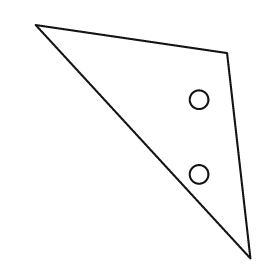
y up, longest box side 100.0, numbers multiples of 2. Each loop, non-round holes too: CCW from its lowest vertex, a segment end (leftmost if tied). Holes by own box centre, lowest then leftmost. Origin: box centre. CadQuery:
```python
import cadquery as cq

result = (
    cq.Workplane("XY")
    .moveTo(46.0, -50.0)
    .lineTo(36.0, 38.0)
    .lineTo(-46.0, 50.0)
    .close()
    .moveTo(24.0, -14.0)
    .circle(4.0)
    .moveTo(24.0, 18.0)
    .circle(4.0)
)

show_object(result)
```